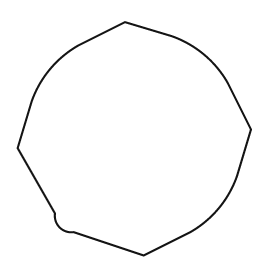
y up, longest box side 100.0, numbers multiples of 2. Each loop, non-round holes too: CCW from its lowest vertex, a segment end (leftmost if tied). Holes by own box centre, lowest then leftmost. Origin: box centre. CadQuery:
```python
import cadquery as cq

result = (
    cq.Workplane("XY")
    .moveTo(4.0, -50.0)
    .lineTo(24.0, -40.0)
    .threePointArc((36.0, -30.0), (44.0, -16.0))
    .lineTo(50.0, 4.0)
    .lineTo(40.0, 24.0)
    .threePointArc((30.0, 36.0), (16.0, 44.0))
    .lineTo(-4.0, 50.0)
    .lineTo(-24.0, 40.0)
    .threePointArc((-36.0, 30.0), (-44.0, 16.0))
    .lineTo(-50.0, -4.0)
    .lineTo(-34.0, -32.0)
    .threePointArc((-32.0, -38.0), (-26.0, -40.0))
    .close()
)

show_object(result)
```